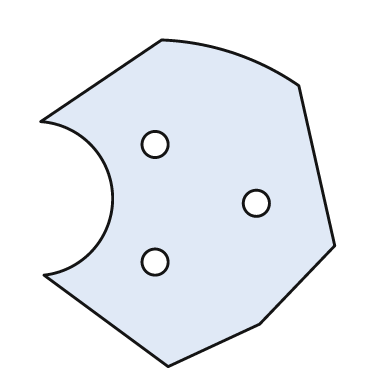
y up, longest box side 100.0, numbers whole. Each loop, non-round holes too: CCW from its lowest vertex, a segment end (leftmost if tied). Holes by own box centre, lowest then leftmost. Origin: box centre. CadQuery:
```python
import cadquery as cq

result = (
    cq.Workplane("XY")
    .moveTo(-6.0, -50.0)
    .lineTo(22.0, -37.0)
    .lineTo(45.0, -13.0)
    .lineTo(34.0, 36.0)
    .threePointArc((14.0, 46.0), (-8.0, 50.0))
    .lineTo(-45.0, 25.0)
    .threePointArc((-23.0, 2.0), (-44.0, -22.0))
    .close()
    .moveTo(-10.0, -18.0)
    .circle(4.0)
    .moveTo(21.0, 0.0)
    .circle(4.0)
    .moveTo(-10.0, 18.0)
    .circle(4.0)
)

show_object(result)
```